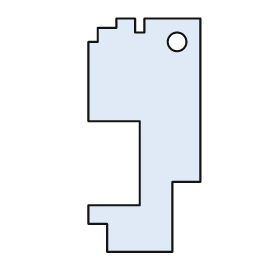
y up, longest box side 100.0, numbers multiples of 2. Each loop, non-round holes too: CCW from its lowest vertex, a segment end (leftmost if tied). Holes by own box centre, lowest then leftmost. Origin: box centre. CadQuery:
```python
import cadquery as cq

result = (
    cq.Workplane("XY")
    .moveTo(-16.0, -50.0)
    .lineTo(12.0, -50.0)
    .lineTo(12.0, -20.0)
    .lineTo(24.0, -20.0)
    .lineTo(24.0, 50.0)
    .lineTo(0.0, 50.0)
    .lineTo(0.0, 44.0)
    .lineTo(-4.0, 44.0)
    .lineTo(-4.0, 50.0)
    .lineTo(-12.0, 50.0)
    .lineTo(-12.0, 46.0)
    .lineTo(-20.0, 46.0)
    .lineTo(-20.0, 40.0)
    .lineTo(-24.0, 40.0)
    .lineTo(-24.0, 6.0)
    .lineTo(-2.0, 6.0)
    .lineTo(-2.0, -30.0)
    .lineTo(-24.0, -30.0)
    .lineTo(-24.0, -38.0)
    .lineTo(-16.0, -38.0)
    .close()
    .moveTo(14.0, 40.0)
    .circle(4.0)
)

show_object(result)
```